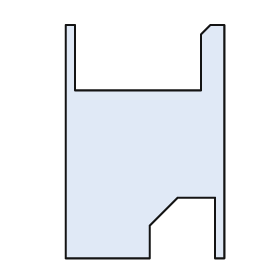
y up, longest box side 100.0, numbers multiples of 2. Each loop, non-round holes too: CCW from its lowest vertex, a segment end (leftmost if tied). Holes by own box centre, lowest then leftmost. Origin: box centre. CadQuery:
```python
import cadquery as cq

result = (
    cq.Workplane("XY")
    .moveTo(-34.0, -50.0)
    .lineTo(2.0, -50.0)
    .lineTo(2.0, -36.0)
    .lineTo(14.0, -24.0)
    .lineTo(30.0, -24.0)
    .lineTo(30.0, -50.0)
    .lineTo(34.0, -50.0)
    .lineTo(34.0, 50.0)
    .lineTo(28.0, 50.0)
    .lineTo(24.0, 46.0)
    .lineTo(24.0, 22.0)
    .lineTo(-30.0, 22.0)
    .lineTo(-30.0, 50.0)
    .lineTo(-34.0, 50.0)
    .close()
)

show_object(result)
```